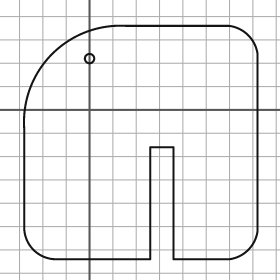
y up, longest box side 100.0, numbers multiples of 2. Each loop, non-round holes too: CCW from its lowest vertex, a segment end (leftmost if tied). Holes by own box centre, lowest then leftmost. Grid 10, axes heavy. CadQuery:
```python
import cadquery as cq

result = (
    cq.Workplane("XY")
    .moveTo(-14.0, -64.0)
    .lineTo(26.0, -64.0)
    .lineTo(26.0, -16.0)
    .lineTo(36.0, -16.0)
    .lineTo(36.0, -64.0)
    .lineTo(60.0, -64.0)
    .threePointArc((68.0, -60.0), (72.0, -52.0))
    .lineTo(72.0, 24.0)
    .threePointArc((68.0, 32.0), (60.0, 36.0))
    .lineTo(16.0, 36.0)
    .threePointArc((-16.0, 24.0), (-28.0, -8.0))
    .lineTo(-28.0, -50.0)
    .threePointArc((-24.0, -60.0), (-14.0, -64.0))
    .close()
    .moveTo(0.0, 22.0)
    .circle(2.0)
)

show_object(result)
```